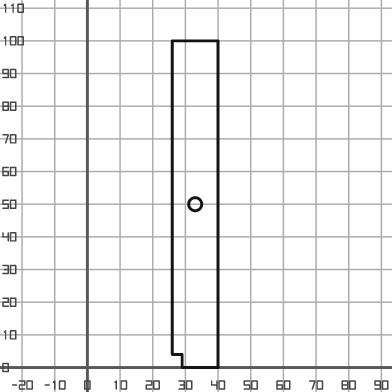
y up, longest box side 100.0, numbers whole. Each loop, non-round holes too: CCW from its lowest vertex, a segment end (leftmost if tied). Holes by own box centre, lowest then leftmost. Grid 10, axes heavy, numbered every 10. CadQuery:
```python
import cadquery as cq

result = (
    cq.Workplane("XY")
    .moveTo(29.0, 0.0)
    .lineTo(40.0, 0.0)
    .lineTo(40.0, 100.0)
    .lineTo(26.0, 100.0)
    .lineTo(26.0, 4.0)
    .lineTo(29.0, 4.0)
    .close()
    .moveTo(33.0, 50.0)
    .circle(2.0)
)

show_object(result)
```